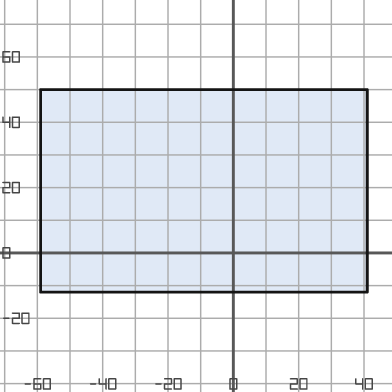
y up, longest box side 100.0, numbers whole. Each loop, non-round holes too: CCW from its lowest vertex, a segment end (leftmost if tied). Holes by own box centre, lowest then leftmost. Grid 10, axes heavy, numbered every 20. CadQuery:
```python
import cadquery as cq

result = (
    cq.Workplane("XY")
    .moveTo(-59.0, -12.0)
    .lineTo(41.0, -12.0)
    .lineTo(41.0, 50.0)
    .lineTo(-59.0, 50.0)
    .close()
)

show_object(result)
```